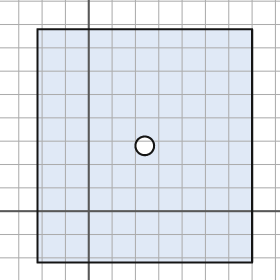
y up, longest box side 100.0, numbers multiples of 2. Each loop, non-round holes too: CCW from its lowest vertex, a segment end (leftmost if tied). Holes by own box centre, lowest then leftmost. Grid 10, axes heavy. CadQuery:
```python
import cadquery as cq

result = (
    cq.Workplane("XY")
    .moveTo(-22.0, -22.0)
    .lineTo(70.0, -22.0)
    .lineTo(70.0, 78.0)
    .lineTo(-22.0, 78.0)
    .close()
    .moveTo(24.0, 28.0)
    .circle(4.0)
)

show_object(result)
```